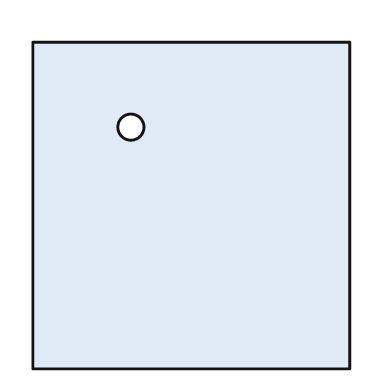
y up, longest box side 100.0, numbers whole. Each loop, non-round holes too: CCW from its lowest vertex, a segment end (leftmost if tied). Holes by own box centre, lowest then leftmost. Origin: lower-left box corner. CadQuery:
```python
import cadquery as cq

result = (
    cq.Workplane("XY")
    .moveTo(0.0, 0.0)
    .lineTo(97.0, 0.0)
    .lineTo(97.0, 100.0)
    .lineTo(0.0, 100.0)
    .close()
    .moveTo(30.0, 74.0)
    .circle(4.0)
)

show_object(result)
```